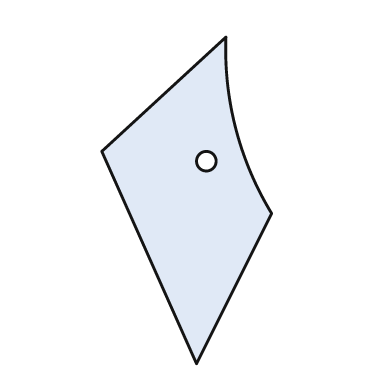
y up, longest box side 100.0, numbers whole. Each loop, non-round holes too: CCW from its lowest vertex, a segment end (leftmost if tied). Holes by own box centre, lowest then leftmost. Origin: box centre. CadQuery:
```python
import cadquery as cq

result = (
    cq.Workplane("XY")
    .moveTo(3.0, -50.0)
    .lineTo(26.0, -4.0)
    .threePointArc((15.0, 22.0), (12.0, 50.0))
    .lineTo(-26.0, 15.0)
    .close()
    .moveTo(6.0, 12.0)
    .circle(3.0)
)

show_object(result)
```